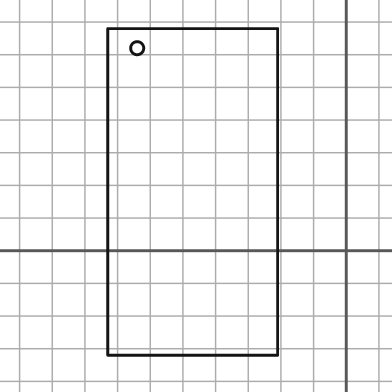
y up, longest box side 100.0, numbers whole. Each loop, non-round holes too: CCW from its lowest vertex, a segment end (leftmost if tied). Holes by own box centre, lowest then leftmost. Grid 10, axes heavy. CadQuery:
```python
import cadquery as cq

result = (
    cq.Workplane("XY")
    .moveTo(-73.0, -32.0)
    .lineTo(-21.0, -32.0)
    .lineTo(-21.0, 68.0)
    .lineTo(-73.0, 68.0)
    .close()
    .moveTo(-64.0, 62.0)
    .circle(2.0)
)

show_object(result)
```